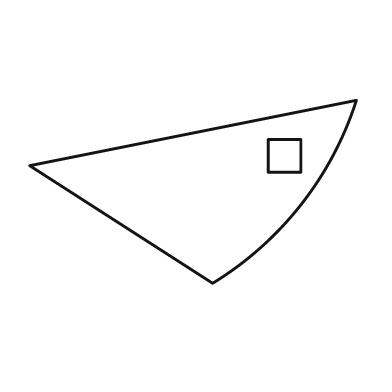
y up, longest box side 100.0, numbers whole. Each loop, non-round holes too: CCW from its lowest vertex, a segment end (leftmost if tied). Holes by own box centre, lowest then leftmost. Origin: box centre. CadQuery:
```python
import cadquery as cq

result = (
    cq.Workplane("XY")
    .moveTo(6.0, -28.0)
    .threePointArc((33.0, -4.0), (50.0, 28.0))
    .lineTo(-50.0, 8.0)
    .close()
    .moveTo(23.0, 6.0)
    .lineTo(33.0, 6.0)
    .lineTo(33.0, 16.0)
    .lineTo(23.0, 16.0)
    .close()
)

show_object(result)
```